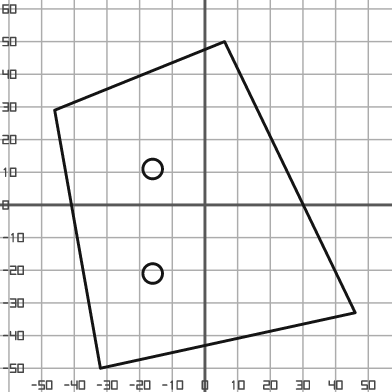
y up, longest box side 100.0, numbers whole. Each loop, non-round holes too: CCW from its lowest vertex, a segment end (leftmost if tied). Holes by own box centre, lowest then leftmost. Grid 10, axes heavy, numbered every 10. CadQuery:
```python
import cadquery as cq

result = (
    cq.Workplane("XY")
    .moveTo(-32.0, -50.0)
    .lineTo(46.0, -33.0)
    .lineTo(6.0, 50.0)
    .lineTo(-46.0, 29.0)
    .close()
    .moveTo(-16.0, -21.0)
    .circle(3.0)
    .moveTo(-16.0, 11.0)
    .circle(3.0)
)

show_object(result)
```